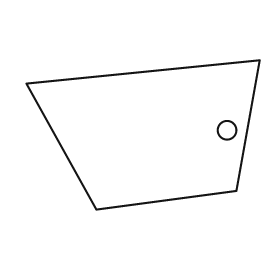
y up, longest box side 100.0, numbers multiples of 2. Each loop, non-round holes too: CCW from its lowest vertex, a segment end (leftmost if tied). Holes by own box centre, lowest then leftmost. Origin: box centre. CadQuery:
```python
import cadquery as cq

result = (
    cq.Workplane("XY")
    .moveTo(-20.0, -32.0)
    .lineTo(40.0, -24.0)
    .lineTo(50.0, 32.0)
    .lineTo(-50.0, 22.0)
    .close()
    .moveTo(36.0, 2.0)
    .circle(4.0)
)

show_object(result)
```